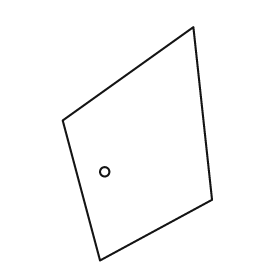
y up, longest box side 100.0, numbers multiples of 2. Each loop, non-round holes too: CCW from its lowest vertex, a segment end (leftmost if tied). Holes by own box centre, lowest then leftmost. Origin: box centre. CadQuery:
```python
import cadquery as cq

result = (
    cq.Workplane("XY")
    .moveTo(-16.0, -50.0)
    .lineTo(32.0, -24.0)
    .lineTo(24.0, 50.0)
    .lineTo(-32.0, 10.0)
    .close()
    .moveTo(-14.0, -12.0)
    .circle(2.0)
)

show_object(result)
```